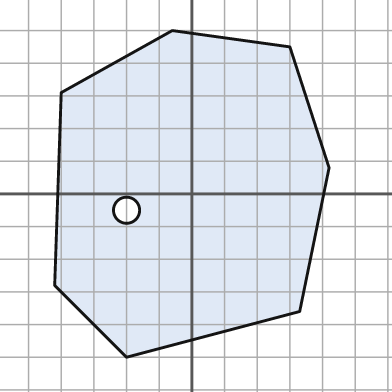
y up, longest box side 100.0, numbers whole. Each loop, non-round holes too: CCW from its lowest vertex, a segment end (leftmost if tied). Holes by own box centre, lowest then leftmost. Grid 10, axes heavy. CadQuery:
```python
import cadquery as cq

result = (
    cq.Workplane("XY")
    .moveTo(-20.0, -50.0)
    .lineTo(33.0, -36.0)
    .lineTo(42.0, 8.0)
    .lineTo(30.0, 45.0)
    .lineTo(-6.0, 50.0)
    .lineTo(-40.0, 31.0)
    .lineTo(-42.0, -28.0)
    .close()
    .moveTo(-20.0, -5.0)
    .circle(4.0)
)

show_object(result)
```